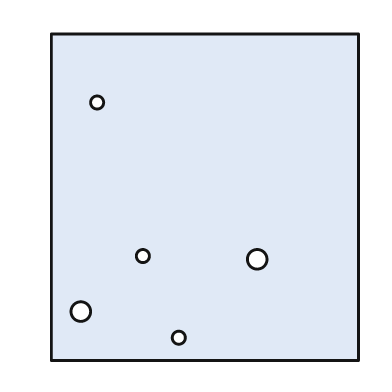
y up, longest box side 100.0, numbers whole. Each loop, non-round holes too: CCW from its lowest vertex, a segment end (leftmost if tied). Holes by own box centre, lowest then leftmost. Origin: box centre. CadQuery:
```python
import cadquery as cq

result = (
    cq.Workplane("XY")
    .moveTo(-47.0, -50.0)
    .lineTo(47.0, -50.0)
    .lineTo(47.0, 50.0)
    .lineTo(-47.0, 50.0)
    .close()
    .moveTo(-8.0, -43.0)
    .circle(2.0)
    .moveTo(-38.0, -35.0)
    .circle(3.0)
    .moveTo(16.0, -19.0)
    .circle(3.0)
    .moveTo(-19.0, -18.0)
    .circle(2.0)
    .moveTo(-33.0, 29.0)
    .circle(2.0)
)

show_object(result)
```